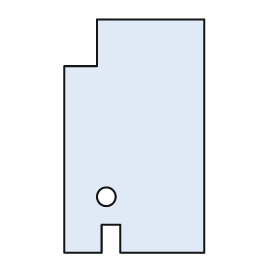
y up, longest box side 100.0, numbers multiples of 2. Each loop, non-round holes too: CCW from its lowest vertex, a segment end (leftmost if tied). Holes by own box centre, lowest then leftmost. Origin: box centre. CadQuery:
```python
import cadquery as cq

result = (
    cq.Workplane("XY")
    .moveTo(-30.0, -50.0)
    .lineTo(-14.0, -50.0)
    .lineTo(-14.0, -38.0)
    .lineTo(-6.0, -38.0)
    .lineTo(-6.0, -50.0)
    .lineTo(30.0, -50.0)
    .lineTo(30.0, 50.0)
    .lineTo(-16.0, 50.0)
    .lineTo(-16.0, 30.0)
    .lineTo(-30.0, 30.0)
    .close()
    .moveTo(-12.0, -26.0)
    .circle(4.0)
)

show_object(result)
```